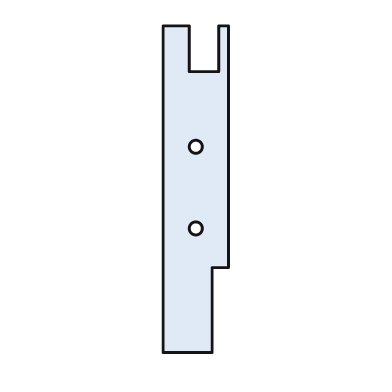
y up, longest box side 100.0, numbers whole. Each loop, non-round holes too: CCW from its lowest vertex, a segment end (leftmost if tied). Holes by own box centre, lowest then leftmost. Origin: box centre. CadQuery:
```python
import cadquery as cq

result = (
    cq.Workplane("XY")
    .moveTo(-10.0, -50.0)
    .lineTo(5.0, -50.0)
    .lineTo(5.0, -24.0)
    .lineTo(10.0, -24.0)
    .lineTo(10.0, 50.0)
    .lineTo(7.0, 50.0)
    .lineTo(7.0, 36.0)
    .lineTo(-2.0, 36.0)
    .lineTo(-2.0, 50.0)
    .lineTo(-10.0, 50.0)
    .close()
    .moveTo(0.0, -12.0)
    .circle(2.0)
    .moveTo(0.0, 13.0)
    .circle(2.0)
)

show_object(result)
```